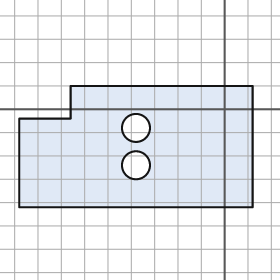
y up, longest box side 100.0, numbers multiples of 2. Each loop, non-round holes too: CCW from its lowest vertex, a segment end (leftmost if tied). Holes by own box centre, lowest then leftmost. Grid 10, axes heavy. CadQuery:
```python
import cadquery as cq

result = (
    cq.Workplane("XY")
    .moveTo(-88.0, -42.0)
    .lineTo(12.0, -42.0)
    .lineTo(12.0, 10.0)
    .lineTo(-66.0, 10.0)
    .lineTo(-66.0, -4.0)
    .lineTo(-88.0, -4.0)
    .close()
    .moveTo(-38.0, -24.0)
    .circle(6.0)
    .moveTo(-38.0, -8.0)
    .circle(6.0)
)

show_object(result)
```